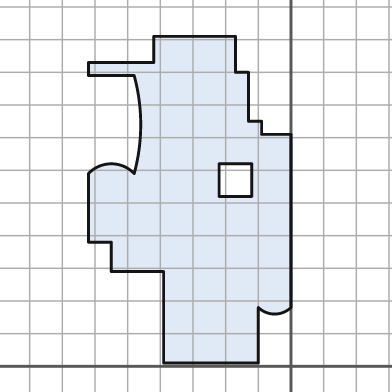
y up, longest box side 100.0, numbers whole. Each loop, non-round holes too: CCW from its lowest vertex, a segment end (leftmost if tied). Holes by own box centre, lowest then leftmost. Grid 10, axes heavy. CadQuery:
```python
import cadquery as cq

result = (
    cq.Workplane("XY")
    .moveTo(-39.0, 1.0)
    .lineTo(-10.0, 1.0)
    .lineTo(-10.0, 18.0)
    .threePointArc((-5.0, 16.0), (0.0, 18.0))
    .lineTo(0.0, 71.0)
    .lineTo(-9.0, 71.0)
    .lineTo(-9.0, 75.0)
    .lineTo(-13.0, 75.0)
    .lineTo(-13.0, 90.0)
    .lineTo(-17.0, 90.0)
    .lineTo(-17.0, 101.0)
    .lineTo(-42.0, 101.0)
    .lineTo(-42.0, 93.0)
    .lineTo(-62.0, 93.0)
    .lineTo(-62.0, 89.0)
    .lineTo(-48.0, 89.0)
    .threePointArc((-46.0, 74.0), (-48.0, 59.0))
    .threePointArc((-55.0, 62.0), (-62.0, 59.0))
    .lineTo(-62.0, 38.0)
    .lineTo(-55.0, 38.0)
    .lineTo(-55.0, 29.0)
    .lineTo(-39.0, 29.0)
    .close()
    .moveTo(-22.0, 52.0)
    .lineTo(-12.0, 52.0)
    .lineTo(-12.0, 62.0)
    .lineTo(-22.0, 62.0)
    .close()
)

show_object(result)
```